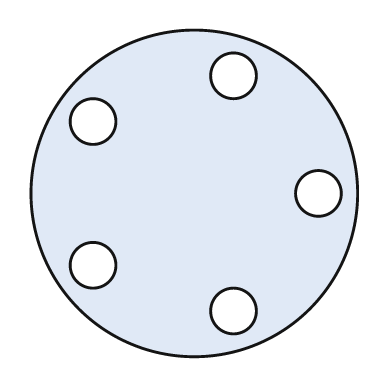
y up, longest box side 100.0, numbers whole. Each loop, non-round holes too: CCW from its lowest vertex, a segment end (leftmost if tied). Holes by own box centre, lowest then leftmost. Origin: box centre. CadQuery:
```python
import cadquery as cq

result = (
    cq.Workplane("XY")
    .moveTo(0.0, 0.0)
    .circle(50.0)
    .moveTo(12.0, -36.0)
    .circle(7.0)
    .moveTo(-31.0, -22.0)
    .circle(7.0)
    .moveTo(38.0, 0.0)
    .circle(7.0)
    .moveTo(-31.0, 22.0)
    .circle(7.0)
    .moveTo(12.0, 36.0)
    .circle(7.0)
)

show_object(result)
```